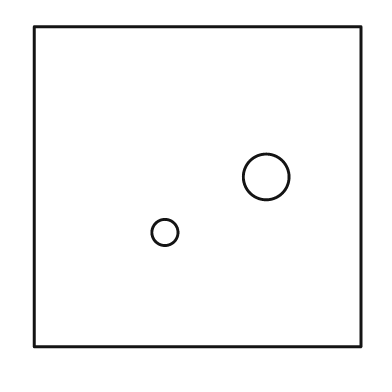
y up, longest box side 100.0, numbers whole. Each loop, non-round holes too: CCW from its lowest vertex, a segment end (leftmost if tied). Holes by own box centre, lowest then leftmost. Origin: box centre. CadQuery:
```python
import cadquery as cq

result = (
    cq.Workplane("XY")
    .moveTo(-50.0, -49.0)
    .lineTo(50.0, -49.0)
    .lineTo(50.0, 49.0)
    .lineTo(-50.0, 49.0)
    .close()
    .moveTo(-10.0, -14.0)
    .circle(4.0)
    .moveTo(21.0, 3.0)
    .circle(7.0)
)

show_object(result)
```